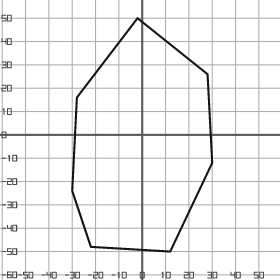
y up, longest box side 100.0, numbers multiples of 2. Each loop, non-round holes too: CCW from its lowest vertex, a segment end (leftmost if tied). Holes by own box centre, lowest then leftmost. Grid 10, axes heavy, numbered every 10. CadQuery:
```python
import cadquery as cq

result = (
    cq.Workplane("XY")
    .moveTo(12.0, -50.0)
    .lineTo(30.0, -12.0)
    .lineTo(28.0, 26.0)
    .lineTo(-2.0, 50.0)
    .lineTo(-28.0, 16.0)
    .lineTo(-30.0, -24.0)
    .lineTo(-22.0, -48.0)
    .close()
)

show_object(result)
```